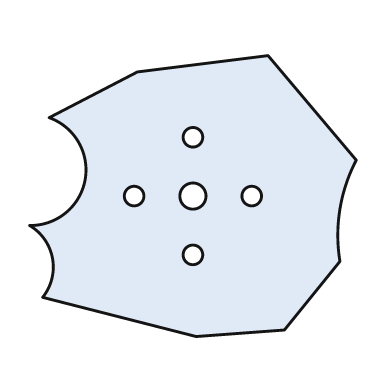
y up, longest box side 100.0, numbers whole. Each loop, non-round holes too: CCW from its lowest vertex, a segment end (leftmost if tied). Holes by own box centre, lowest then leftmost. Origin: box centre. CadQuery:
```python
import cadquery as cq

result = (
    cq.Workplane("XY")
    .moveTo(1.0, -43.0)
    .lineTo(28.0, -41.0)
    .lineTo(45.0, -20.0)
    .threePointArc((45.0, -4.0), (50.0, 11.0))
    .lineTo(23.0, 43.0)
    .lineTo(-17.0, 38.0)
    .lineTo(-44.0, 24.0)
    .threePointArc((-33.0, 5.0), (-50.0, -9.0))
    .threePointArc((-43.0, -19.0), (-46.0, -31.0))
    .close()
    .moveTo(0.0, -18.0)
    .circle(3.0)
    .moveTo(-18.0, 0.0)
    .circle(3.0)
    .moveTo(0.0, 0.0)
    .circle(4.0)
    .moveTo(18.0, 0.0)
    .circle(3.0)
    .moveTo(0.0, 18.0)
    .circle(3.0)
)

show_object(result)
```